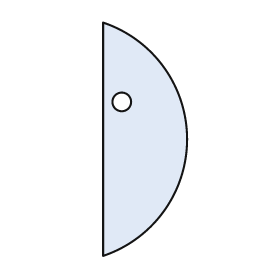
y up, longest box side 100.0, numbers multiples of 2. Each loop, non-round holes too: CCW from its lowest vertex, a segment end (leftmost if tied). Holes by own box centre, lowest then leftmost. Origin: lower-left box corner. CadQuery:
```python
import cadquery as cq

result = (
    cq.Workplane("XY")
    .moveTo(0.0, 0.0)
    .threePointArc((36.0, 50.0), (0.0, 100.0))
    .close()
    .moveTo(8.0, 66.0)
    .circle(4.0)
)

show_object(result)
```